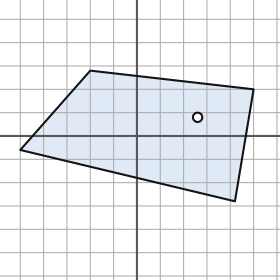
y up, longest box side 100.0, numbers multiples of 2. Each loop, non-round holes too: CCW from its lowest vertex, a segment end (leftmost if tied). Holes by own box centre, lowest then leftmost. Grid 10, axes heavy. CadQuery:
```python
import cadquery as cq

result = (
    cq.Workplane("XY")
    .moveTo(42.0, -28.0)
    .lineTo(50.0, 20.0)
    .lineTo(-20.0, 28.0)
    .lineTo(-50.0, -6.0)
    .close()
    .moveTo(26.0, 8.0)
    .circle(2.0)
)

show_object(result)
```